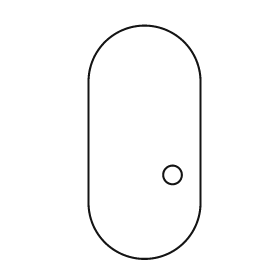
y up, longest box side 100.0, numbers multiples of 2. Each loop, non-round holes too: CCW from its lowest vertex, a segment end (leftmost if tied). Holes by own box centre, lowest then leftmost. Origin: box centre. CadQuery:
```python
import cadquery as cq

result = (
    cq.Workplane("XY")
    .moveTo(-24.0, -26.0)
    .threePointArc((0.0, -50.0), (24.0, -26.0))
    .lineTo(24.0, 26.0)
    .threePointArc((0.0, 50.0), (-24.0, 26.0))
    .close()
    .moveTo(12.0, -14.0)
    .circle(4.0)
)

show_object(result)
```